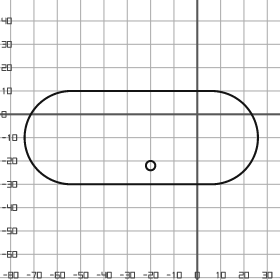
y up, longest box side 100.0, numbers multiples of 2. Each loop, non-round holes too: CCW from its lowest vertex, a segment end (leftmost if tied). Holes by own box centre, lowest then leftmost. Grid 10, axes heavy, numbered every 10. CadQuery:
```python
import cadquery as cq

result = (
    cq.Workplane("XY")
    .moveTo(-54.0, -30.0)
    .lineTo(6.0, -30.0)
    .threePointArc((26.0, -10.0), (6.0, 10.0))
    .lineTo(-54.0, 10.0)
    .threePointArc((-74.0, -10.0), (-54.0, -30.0))
    .close()
    .moveTo(-20.0, -22.0)
    .circle(2.0)
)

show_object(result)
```